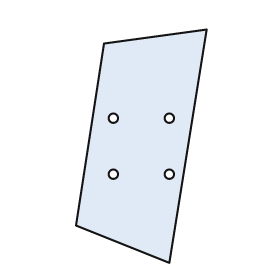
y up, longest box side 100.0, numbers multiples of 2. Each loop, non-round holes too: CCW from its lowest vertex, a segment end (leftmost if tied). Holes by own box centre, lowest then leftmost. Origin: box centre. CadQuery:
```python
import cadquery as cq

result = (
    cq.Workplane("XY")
    .moveTo(12.0, -50.0)
    .lineTo(28.0, 50.0)
    .lineTo(-16.0, 44.0)
    .lineTo(-28.0, -34.0)
    .close()
    .moveTo(-12.0, -12.0)
    .circle(2.0)
    .moveTo(12.0, -12.0)
    .circle(2.0)
    .moveTo(-12.0, 12.0)
    .circle(2.0)
    .moveTo(12.0, 12.0)
    .circle(2.0)
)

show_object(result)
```